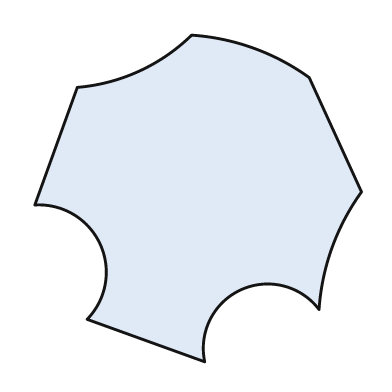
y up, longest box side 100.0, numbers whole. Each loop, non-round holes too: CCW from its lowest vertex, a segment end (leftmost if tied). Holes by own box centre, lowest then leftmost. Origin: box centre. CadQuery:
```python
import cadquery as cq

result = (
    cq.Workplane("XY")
    .moveTo(2.0, -50.0)
    .threePointArc((13.0, -28.0), (37.0, -34.0))
    .threePointArc((41.0, -15.0), (50.0, 2.0))
    .lineTo(34.0, 37.0)
    .threePointArc((17.0, 46.0), (-2.0, 50.0))
    .threePointArc((-18.0, 39.0), (-37.0, 34.0))
    .lineTo(-50.0, -2.0)
    .threePointArc((-30.0, -14.0), (-34.0, -37.0))
    .close()
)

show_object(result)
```